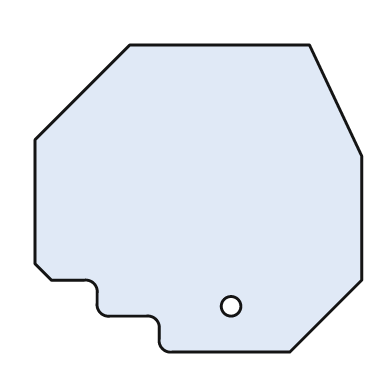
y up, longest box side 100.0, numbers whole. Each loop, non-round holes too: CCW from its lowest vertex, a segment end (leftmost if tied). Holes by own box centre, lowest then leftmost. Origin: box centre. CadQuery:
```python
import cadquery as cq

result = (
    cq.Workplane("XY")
    .moveTo(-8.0, -47.0)
    .lineTo(28.0, -47.0)
    .lineTo(50.0, -25.0)
    .lineTo(50.0, 13.0)
    .lineTo(34.0, 47.0)
    .lineTo(-21.0, 47.0)
    .lineTo(-50.0, 18.0)
    .lineTo(-50.0, -20.0)
    .lineTo(-45.0, -25.0)
    .lineTo(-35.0, -25.0)
    .threePointArc((-32.0, -26.0), (-31.0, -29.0))
    .lineTo(-31.0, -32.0)
    .threePointArc((-30.0, -35.0), (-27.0, -36.0))
    .lineTo(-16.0, -36.0)
    .threePointArc((-13.0, -37.0), (-12.0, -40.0))
    .lineTo(-12.0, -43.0)
    .threePointArc((-11.0, -46.0), (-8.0, -47.0))
    .close()
    .moveTo(10.0, -33.0)
    .circle(3.0)
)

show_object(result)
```